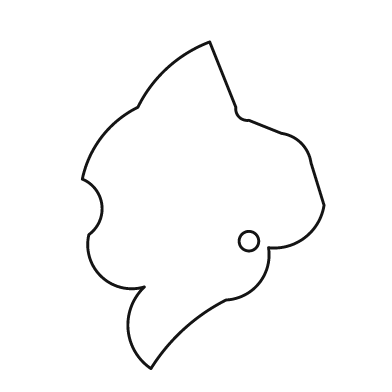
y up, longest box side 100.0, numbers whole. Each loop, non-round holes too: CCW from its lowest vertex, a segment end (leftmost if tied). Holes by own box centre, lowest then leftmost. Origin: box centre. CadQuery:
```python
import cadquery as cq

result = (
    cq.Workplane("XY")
    .moveTo(-16.0, -50.0)
    .threePointArc((-6.0, -38.0), (7.0, -29.0))
    .threePointArc((17.0, -24.0), (20.0, -13.0))
    .threePointArc((31.0, -10.0), (37.0, 0.0))
    .lineTo(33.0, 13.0)
    .threePointArc((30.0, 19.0), (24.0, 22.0))
    .lineTo(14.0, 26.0)
    .threePointArc((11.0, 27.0), (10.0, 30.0))
    .lineTo(2.0, 50.0)
    .threePointArc((-11.0, 42.0), (-20.0, 30.0))
    .threePointArc((-31.0, 21.0), (-37.0, 8.0))
    .threePointArc((-31.0, 0.0), (-35.0, -9.0))
    .threePointArc((-31.0, -22.0), (-18.0, -25.0))
    .threePointArc((-23.0, -38.0), (-16.0, -50.0))
    .close()
    .moveTo(14.0, -11.0)
    .circle(3.0)
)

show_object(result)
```